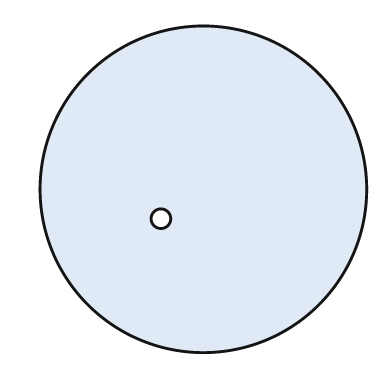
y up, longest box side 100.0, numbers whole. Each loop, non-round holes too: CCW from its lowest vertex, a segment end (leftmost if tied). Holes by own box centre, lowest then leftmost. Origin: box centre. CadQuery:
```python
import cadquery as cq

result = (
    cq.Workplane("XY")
    .moveTo(0.0, 0.0)
    .circle(50.0)
    .moveTo(-13.0, -9.0)
    .circle(3.0)
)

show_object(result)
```